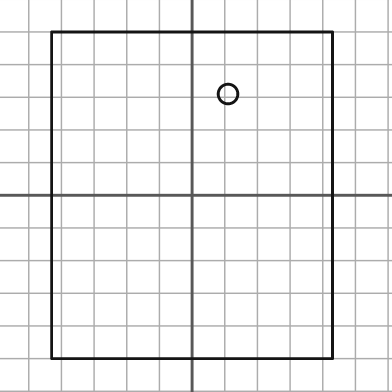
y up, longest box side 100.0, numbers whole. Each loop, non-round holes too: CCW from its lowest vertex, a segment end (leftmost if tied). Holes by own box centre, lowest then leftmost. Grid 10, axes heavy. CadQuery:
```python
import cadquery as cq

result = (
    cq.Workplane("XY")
    .moveTo(-43.0, -50.0)
    .lineTo(43.0, -50.0)
    .lineTo(43.0, 50.0)
    .lineTo(-43.0, 50.0)
    .close()
    .moveTo(11.0, 31.0)
    .circle(3.0)
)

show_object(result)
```